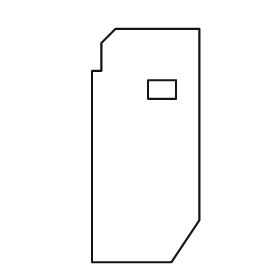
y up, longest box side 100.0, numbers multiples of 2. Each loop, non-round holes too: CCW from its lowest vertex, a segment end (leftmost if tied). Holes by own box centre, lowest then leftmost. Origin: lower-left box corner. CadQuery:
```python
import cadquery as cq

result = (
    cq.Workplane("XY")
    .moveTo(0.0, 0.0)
    .lineTo(34.0, 0.0)
    .lineTo(46.0, 18.0)
    .lineTo(46.0, 100.0)
    .lineTo(10.0, 100.0)
    .lineTo(4.0, 94.0)
    .lineTo(4.0, 82.0)
    .lineTo(0.0, 82.0)
    .close()
    .moveTo(24.0, 70.0)
    .lineTo(36.0, 70.0)
    .lineTo(36.0, 78.0)
    .lineTo(24.0, 78.0)
    .close()
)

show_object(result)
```